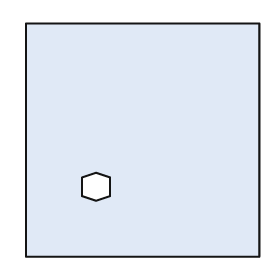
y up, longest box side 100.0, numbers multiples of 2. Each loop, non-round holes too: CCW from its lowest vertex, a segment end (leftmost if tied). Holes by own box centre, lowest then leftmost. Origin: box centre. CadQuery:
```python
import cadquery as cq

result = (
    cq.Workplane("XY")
    .moveTo(-50.0, -50.0)
    .lineTo(50.0, -50.0)
    .lineTo(50.0, 50.0)
    .lineTo(-50.0, 50.0)
    .close()
    .moveTo(-20.0, -26.0)
    .lineTo(-14.0, -24.0)
    .lineTo(-14.0, -16.0)
    .lineTo(-20.0, -14.0)
    .lineTo(-26.0, -16.0)
    .lineTo(-26.0, -24.0)
    .close()
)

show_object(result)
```